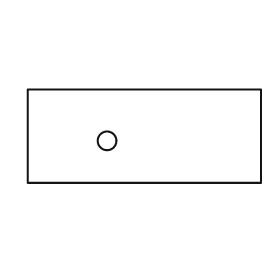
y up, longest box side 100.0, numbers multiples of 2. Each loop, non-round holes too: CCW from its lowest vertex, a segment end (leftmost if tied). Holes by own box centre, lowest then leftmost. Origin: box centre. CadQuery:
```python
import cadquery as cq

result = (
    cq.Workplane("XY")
    .moveTo(-50.0, -20.0)
    .lineTo(50.0, -20.0)
    .lineTo(50.0, 20.0)
    .lineTo(-50.0, 20.0)
    .close()
    .moveTo(-16.0, -2.0)
    .circle(4.0)
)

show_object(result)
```